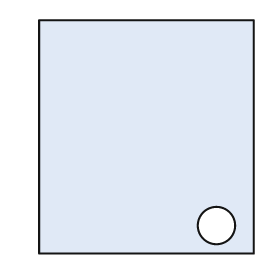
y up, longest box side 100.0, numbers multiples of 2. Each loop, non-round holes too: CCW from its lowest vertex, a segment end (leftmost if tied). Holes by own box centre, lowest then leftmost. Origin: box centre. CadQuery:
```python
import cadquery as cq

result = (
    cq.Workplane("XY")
    .moveTo(-46.0, -50.0)
    .lineTo(46.0, -50.0)
    .lineTo(46.0, 50.0)
    .lineTo(-46.0, 50.0)
    .close()
    .moveTo(30.0, -38.0)
    .circle(8.0)
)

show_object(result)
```